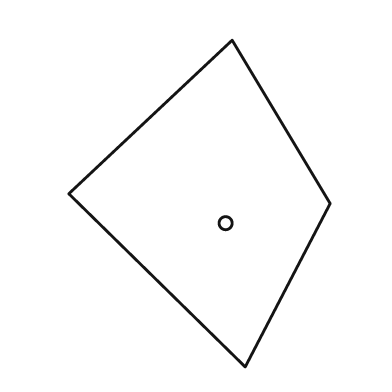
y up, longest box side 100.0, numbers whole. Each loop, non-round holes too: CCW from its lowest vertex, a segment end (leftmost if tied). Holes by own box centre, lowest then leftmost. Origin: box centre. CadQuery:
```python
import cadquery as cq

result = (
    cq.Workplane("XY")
    .moveTo(14.0, -50.0)
    .lineTo(40.0, 0.0)
    .lineTo(10.0, 50.0)
    .lineTo(-40.0, 3.0)
    .close()
    .moveTo(8.0, -6.0)
    .circle(2.0)
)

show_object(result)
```